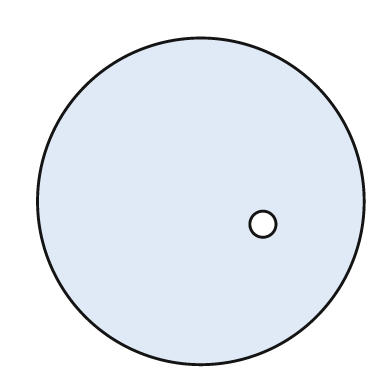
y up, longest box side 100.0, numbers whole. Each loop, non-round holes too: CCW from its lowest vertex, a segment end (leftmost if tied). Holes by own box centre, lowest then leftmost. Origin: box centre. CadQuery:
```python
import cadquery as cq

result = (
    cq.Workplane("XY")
    .moveTo(0.0, 0.0)
    .circle(50.0)
    .moveTo(19.0, -7.0)
    .circle(4.0)
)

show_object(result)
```